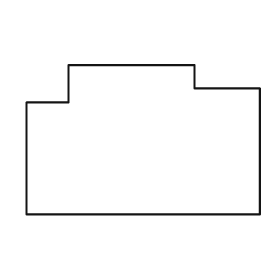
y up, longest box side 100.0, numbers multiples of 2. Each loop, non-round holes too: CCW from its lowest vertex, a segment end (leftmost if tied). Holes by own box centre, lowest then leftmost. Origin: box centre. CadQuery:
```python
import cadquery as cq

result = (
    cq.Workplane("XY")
    .moveTo(-50.0, -32.0)
    .lineTo(50.0, -32.0)
    .lineTo(50.0, 22.0)
    .lineTo(22.0, 22.0)
    .lineTo(22.0, 32.0)
    .lineTo(-32.0, 32.0)
    .lineTo(-32.0, 16.0)
    .lineTo(-50.0, 16.0)
    .close()
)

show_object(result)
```